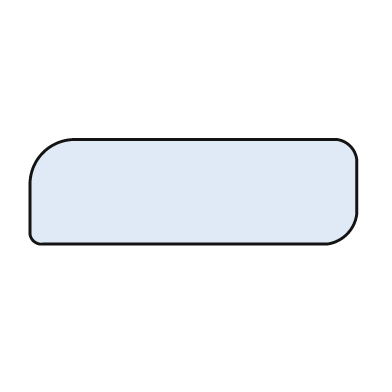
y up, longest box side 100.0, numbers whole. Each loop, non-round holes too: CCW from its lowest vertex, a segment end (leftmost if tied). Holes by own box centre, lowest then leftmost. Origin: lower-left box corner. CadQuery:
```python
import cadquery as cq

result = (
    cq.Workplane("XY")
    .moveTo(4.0, 0.0)
    .lineTo(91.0, 0.0)
    .threePointArc((97.0, 3.0), (100.0, 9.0))
    .lineTo(100.0, 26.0)
    .threePointArc((98.0, 30.0), (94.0, 32.0))
    .lineTo(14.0, 32.0)
    .threePointArc((4.0, 28.0), (0.0, 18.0))
    .lineTo(0.0, 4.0)
    .threePointArc((1.0, 1.0), (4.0, 0.0))
    .close()
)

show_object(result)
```